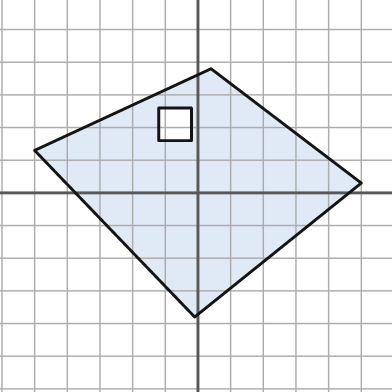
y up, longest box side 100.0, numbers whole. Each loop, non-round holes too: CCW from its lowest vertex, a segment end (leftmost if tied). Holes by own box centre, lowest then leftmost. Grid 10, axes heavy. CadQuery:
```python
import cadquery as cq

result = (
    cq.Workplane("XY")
    .moveTo(-1.0, -38.0)
    .lineTo(50.0, 3.0)
    .lineTo(4.0, 38.0)
    .lineTo(-50.0, 13.0)
    .close()
    .moveTo(-12.0, 16.0)
    .lineTo(-2.0, 16.0)
    .lineTo(-2.0, 26.0)
    .lineTo(-12.0, 26.0)
    .close()
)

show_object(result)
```